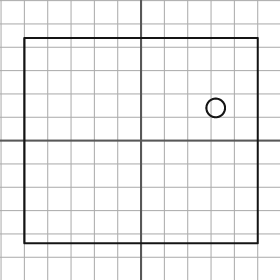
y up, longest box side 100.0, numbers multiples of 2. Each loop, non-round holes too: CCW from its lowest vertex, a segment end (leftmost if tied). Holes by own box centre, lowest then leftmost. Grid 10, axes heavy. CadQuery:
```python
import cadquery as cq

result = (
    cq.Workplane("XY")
    .moveTo(-50.0, -44.0)
    .lineTo(50.0, -44.0)
    .lineTo(50.0, 44.0)
    .lineTo(-50.0, 44.0)
    .close()
    .moveTo(32.0, 14.0)
    .circle(4.0)
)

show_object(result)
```